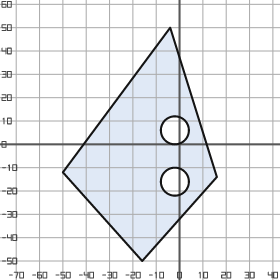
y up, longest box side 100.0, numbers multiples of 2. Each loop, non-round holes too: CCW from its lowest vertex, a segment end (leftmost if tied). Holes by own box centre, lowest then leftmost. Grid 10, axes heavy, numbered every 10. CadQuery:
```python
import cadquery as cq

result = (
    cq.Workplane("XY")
    .moveTo(-16.0, -50.0)
    .lineTo(16.0, -14.0)
    .lineTo(-4.0, 50.0)
    .lineTo(-50.0, -12.0)
    .close()
    .moveTo(-2.0, -16.0)
    .circle(6.0)
    .moveTo(-2.0, 6.0)
    .circle(6.0)
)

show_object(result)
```